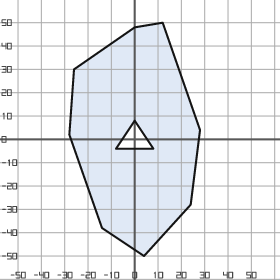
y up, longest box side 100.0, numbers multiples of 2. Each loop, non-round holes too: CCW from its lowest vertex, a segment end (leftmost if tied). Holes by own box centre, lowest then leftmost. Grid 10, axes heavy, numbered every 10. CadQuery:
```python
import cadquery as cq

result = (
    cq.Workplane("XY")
    .moveTo(4.0, -50.0)
    .lineTo(24.0, -28.0)
    .lineTo(28.0, 4.0)
    .lineTo(12.0, 50.0)
    .lineTo(0.0, 48.0)
    .lineTo(-26.0, 30.0)
    .lineTo(-28.0, 2.0)
    .lineTo(-14.0, -38.0)
    .close()
    .moveTo(-8.0, -4.0)
    .lineTo(8.0, -4.0)
    .lineTo(0.0, 8.0)
    .close()
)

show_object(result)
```